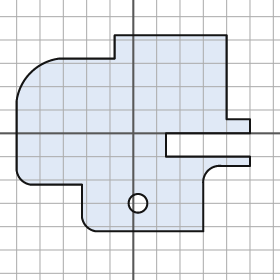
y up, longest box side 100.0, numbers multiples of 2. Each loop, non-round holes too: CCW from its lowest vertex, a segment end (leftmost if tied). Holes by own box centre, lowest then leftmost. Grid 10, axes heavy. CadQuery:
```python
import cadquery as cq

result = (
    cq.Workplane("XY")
    .moveTo(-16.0, -42.0)
    .lineTo(30.0, -42.0)
    .lineTo(30.0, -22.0)
    .threePointArc((32.0, -16.0), (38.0, -14.0))
    .lineTo(50.0, -14.0)
    .lineTo(50.0, -10.0)
    .lineTo(14.0, -10.0)
    .lineTo(14.0, 0.0)
    .lineTo(50.0, 0.0)
    .lineTo(50.0, 6.0)
    .lineTo(40.0, 6.0)
    .lineTo(40.0, 42.0)
    .lineTo(-8.0, 42.0)
    .lineTo(-8.0, 32.0)
    .lineTo(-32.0, 32.0)
    .threePointArc((-44.0, 26.0), (-50.0, 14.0))
    .lineTo(-50.0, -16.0)
    .threePointArc((-48.0, -20.0), (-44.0, -22.0))
    .lineTo(-22.0, -22.0)
    .lineTo(-22.0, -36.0)
    .threePointArc((-20.0, -40.0), (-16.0, -42.0))
    .close()
    .moveTo(2.0, -30.0)
    .circle(4.0)
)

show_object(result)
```